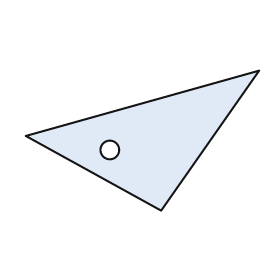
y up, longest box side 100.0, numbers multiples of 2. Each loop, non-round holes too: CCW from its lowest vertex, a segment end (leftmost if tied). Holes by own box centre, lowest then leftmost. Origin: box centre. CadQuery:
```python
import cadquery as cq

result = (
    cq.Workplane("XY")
    .moveTo(8.0, -30.0)
    .lineTo(50.0, 30.0)
    .lineTo(-50.0, 2.0)
    .close()
    .moveTo(-14.0, -4.0)
    .circle(4.0)
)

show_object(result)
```